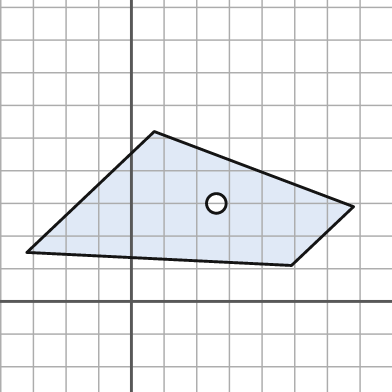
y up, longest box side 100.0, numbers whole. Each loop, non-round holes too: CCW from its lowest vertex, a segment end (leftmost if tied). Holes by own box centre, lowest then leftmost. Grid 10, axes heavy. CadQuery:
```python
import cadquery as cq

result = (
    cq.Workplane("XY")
    .moveTo(49.0, 11.0)
    .lineTo(68.0, 29.0)
    .lineTo(7.0, 52.0)
    .lineTo(-32.0, 15.0)
    .close()
    .moveTo(26.0, 30.0)
    .circle(3.0)
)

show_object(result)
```